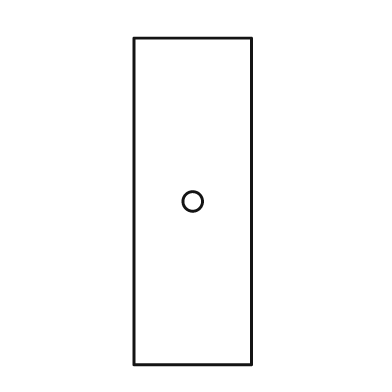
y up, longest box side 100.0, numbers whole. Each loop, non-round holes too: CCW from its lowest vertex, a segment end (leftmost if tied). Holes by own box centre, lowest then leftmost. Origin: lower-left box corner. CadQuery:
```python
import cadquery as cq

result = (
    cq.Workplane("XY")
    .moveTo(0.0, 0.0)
    .lineTo(36.0, 0.0)
    .lineTo(36.0, 100.0)
    .lineTo(0.0, 100.0)
    .close()
    .moveTo(18.0, 50.0)
    .circle(3.0)
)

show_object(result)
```